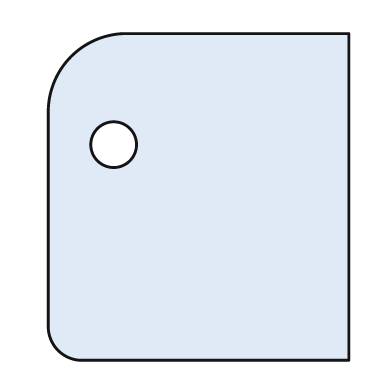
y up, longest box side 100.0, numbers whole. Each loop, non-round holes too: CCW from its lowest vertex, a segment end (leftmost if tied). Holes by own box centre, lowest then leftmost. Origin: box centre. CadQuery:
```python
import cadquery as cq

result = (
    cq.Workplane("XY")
    .moveTo(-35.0, -50.0)
    .lineTo(46.0, -50.0)
    .lineTo(46.0, 50.0)
    .lineTo(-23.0, 50.0)
    .threePointArc((-39.0, 43.0), (-46.0, 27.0))
    .lineTo(-46.0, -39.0)
    .threePointArc((-43.0, -47.0), (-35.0, -50.0))
    .close()
    .moveTo(-26.0, 16.0)
    .circle(7.0)
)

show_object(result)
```